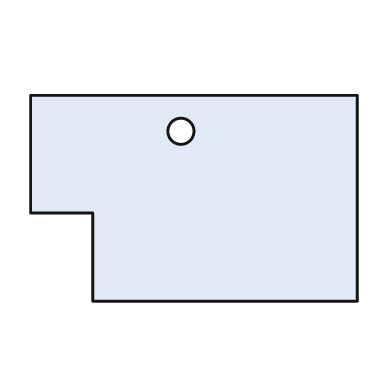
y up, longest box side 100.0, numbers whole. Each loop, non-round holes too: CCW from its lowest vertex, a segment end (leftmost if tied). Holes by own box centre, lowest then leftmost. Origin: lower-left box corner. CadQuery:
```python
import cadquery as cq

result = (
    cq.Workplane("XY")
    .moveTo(19.0, 0.0)
    .lineTo(100.0, 0.0)
    .lineTo(100.0, 63.0)
    .lineTo(0.0, 63.0)
    .lineTo(0.0, 27.0)
    .lineTo(19.0, 27.0)
    .close()
    .moveTo(46.0, 52.0)
    .circle(4.0)
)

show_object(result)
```